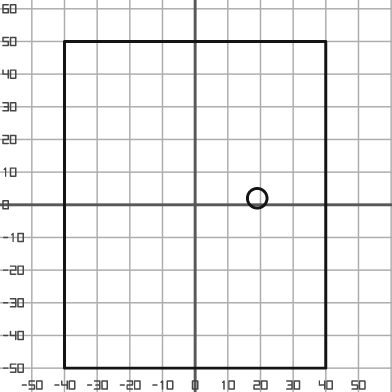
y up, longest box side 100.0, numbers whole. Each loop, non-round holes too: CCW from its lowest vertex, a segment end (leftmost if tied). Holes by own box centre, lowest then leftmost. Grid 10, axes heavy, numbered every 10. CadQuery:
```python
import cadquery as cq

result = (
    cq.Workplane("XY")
    .moveTo(-40.0, -50.0)
    .lineTo(40.0, -50.0)
    .lineTo(40.0, 50.0)
    .lineTo(-40.0, 50.0)
    .close()
    .moveTo(19.0, 2.0)
    .circle(3.0)
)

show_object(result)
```